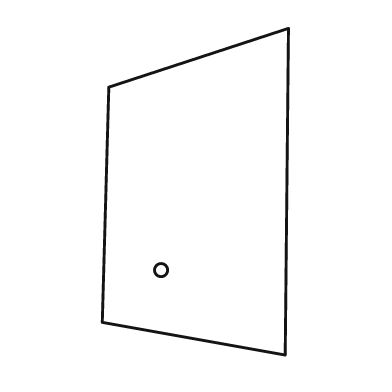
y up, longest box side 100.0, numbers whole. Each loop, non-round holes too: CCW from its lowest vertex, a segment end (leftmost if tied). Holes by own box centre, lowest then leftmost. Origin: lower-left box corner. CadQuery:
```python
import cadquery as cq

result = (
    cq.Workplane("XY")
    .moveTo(56.0, 0.0)
    .lineTo(57.0, 100.0)
    .lineTo(2.0, 82.0)
    .lineTo(0.0, 10.0)
    .close()
    .moveTo(18.0, 26.0)
    .circle(2.0)
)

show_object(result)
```